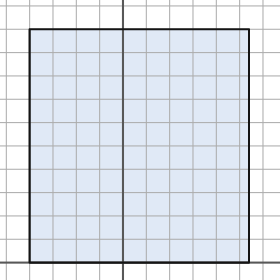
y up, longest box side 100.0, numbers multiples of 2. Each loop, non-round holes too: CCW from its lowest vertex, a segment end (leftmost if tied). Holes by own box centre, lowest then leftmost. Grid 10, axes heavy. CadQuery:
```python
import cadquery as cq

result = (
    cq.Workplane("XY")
    .moveTo(-40.0, 0.0)
    .lineTo(54.0, 0.0)
    .lineTo(54.0, 100.0)
    .lineTo(-40.0, 100.0)
    .close()
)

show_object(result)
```